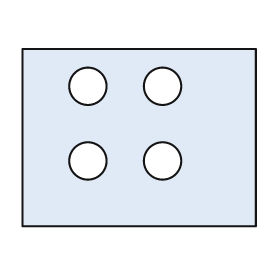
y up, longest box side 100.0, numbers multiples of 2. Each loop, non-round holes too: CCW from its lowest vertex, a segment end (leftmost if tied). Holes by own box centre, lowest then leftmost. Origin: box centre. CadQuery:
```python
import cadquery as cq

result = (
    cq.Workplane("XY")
    .moveTo(-50.0, -38.0)
    .lineTo(50.0, -38.0)
    .lineTo(50.0, 38.0)
    .lineTo(-50.0, 38.0)
    .close()
    .moveTo(-22.0, -10.0)
    .circle(8.0)
    .moveTo(10.0, -10.0)
    .circle(8.0)
    .moveTo(-22.0, 22.0)
    .circle(8.0)
    .moveTo(10.0, 22.0)
    .circle(8.0)
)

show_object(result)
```